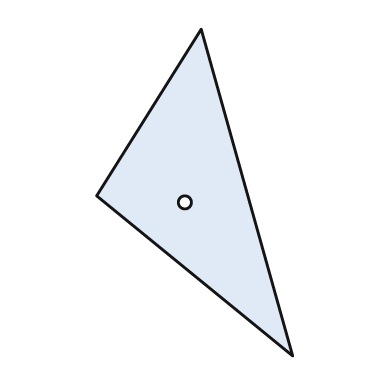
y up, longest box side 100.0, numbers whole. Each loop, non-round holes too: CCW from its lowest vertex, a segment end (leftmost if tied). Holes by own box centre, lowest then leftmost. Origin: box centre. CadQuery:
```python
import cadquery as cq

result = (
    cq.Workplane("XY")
    .moveTo(30.0, -50.0)
    .lineTo(2.0, 50.0)
    .lineTo(-30.0, -1.0)
    .close()
    .moveTo(-3.0, -3.0)
    .circle(2.0)
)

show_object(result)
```